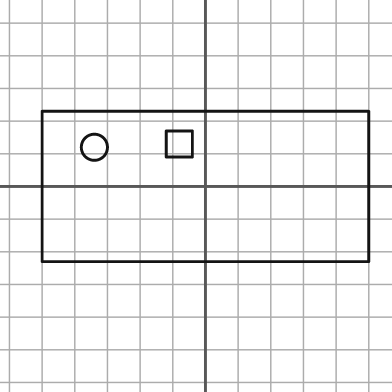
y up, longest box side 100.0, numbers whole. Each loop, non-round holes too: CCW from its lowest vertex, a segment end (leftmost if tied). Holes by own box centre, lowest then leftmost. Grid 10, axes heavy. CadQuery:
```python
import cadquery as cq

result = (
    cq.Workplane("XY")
    .moveTo(-50.0, -23.0)
    .lineTo(50.0, -23.0)
    .lineTo(50.0, 23.0)
    .lineTo(-50.0, 23.0)
    .close()
    .moveTo(-34.0, 12.0)
    .circle(4.0)
    .moveTo(-12.0, 9.0)
    .lineTo(-4.0, 9.0)
    .lineTo(-4.0, 17.0)
    .lineTo(-12.0, 17.0)
    .close()
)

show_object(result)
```